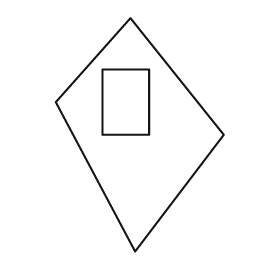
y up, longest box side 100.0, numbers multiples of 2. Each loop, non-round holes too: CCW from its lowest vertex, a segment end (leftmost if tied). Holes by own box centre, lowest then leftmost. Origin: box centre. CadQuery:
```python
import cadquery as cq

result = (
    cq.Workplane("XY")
    .moveTo(-2.0, -50.0)
    .lineTo(36.0, 0.0)
    .lineTo(-4.0, 50.0)
    .lineTo(-36.0, 14.0)
    .close()
    .moveTo(-16.0, 0.0)
    .lineTo(4.0, 0.0)
    .lineTo(4.0, 28.0)
    .lineTo(-16.0, 28.0)
    .close()
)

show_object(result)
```